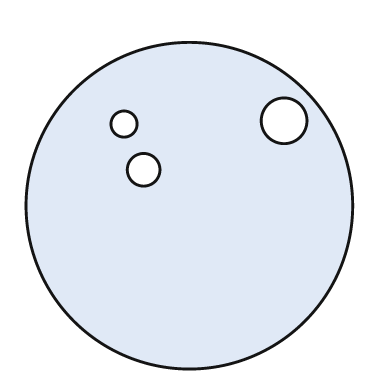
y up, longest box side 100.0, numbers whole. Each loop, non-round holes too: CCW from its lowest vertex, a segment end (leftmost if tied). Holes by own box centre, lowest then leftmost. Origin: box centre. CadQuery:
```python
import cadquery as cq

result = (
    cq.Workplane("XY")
    .moveTo(0.0, 0.0)
    .circle(50.0)
    .moveTo(-14.0, 11.0)
    .circle(5.0)
    .moveTo(-20.0, 25.0)
    .circle(4.0)
    .moveTo(29.0, 26.0)
    .circle(7.0)
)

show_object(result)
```